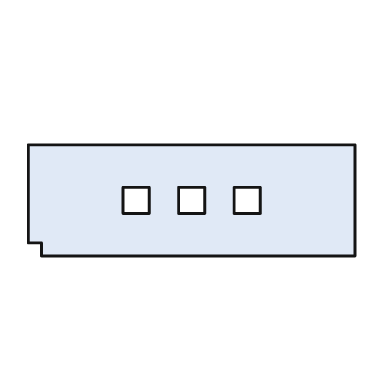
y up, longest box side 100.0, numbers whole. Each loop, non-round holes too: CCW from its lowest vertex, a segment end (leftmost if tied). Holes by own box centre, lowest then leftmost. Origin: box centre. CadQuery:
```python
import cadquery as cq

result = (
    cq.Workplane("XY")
    .moveTo(-46.0, -17.0)
    .lineTo(50.0, -17.0)
    .lineTo(50.0, 17.0)
    .lineTo(-50.0, 17.0)
    .lineTo(-50.0, -13.0)
    .lineTo(-46.0, -13.0)
    .close()
    .moveTo(-21.0, -4.0)
    .lineTo(-13.0, -4.0)
    .lineTo(-13.0, 4.0)
    .lineTo(-21.0, 4.0)
    .close()
    .moveTo(-4.0, -4.0)
    .lineTo(4.0, -4.0)
    .lineTo(4.0, 4.0)
    .lineTo(-4.0, 4.0)
    .close()
    .moveTo(13.0, -4.0)
    .lineTo(21.0, -4.0)
    .lineTo(21.0, 4.0)
    .lineTo(13.0, 4.0)
    .close()
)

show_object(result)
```